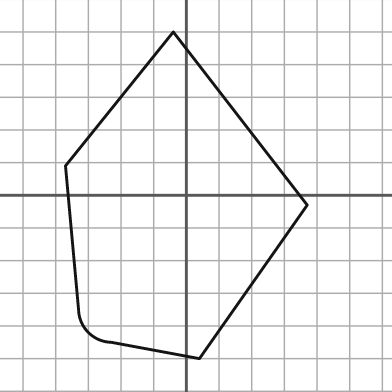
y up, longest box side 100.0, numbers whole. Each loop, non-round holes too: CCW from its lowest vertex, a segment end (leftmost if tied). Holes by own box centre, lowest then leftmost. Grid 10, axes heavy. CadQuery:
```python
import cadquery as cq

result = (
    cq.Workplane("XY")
    .moveTo(4.0, -50.0)
    .lineTo(37.0, -3.0)
    .lineTo(-4.0, 50.0)
    .lineTo(-37.0, 9.0)
    .lineTo(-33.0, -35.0)
    .threePointArc((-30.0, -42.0), (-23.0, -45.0))
    .close()
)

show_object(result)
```